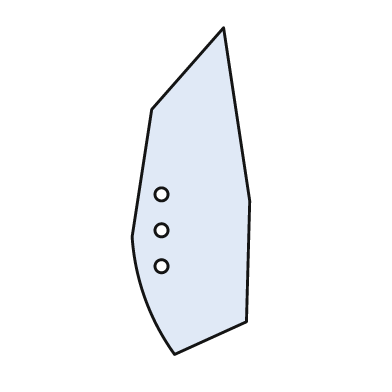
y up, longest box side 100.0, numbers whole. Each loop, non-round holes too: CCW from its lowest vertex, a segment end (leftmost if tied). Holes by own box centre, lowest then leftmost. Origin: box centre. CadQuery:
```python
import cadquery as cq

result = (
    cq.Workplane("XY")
    .moveTo(-5.0, -50.0)
    .lineTo(17.0, -40.0)
    .lineTo(18.0, -3.0)
    .lineTo(10.0, 50.0)
    .lineTo(-12.0, 25.0)
    .lineTo(-18.0, -14.0)
    .threePointArc((-14.0, -33.0), (-5.0, -50.0))
    .close()
    .moveTo(-9.0, -23.0)
    .circle(2.0)
    .moveTo(-9.0, -12.0)
    .circle(2.0)
    .moveTo(-9.0, -1.0)
    .circle(2.0)
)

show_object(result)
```